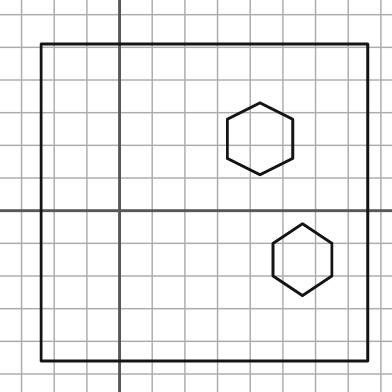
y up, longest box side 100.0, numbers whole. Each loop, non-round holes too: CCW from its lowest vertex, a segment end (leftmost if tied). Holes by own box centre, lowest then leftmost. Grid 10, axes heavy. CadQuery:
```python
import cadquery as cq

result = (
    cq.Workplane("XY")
    .moveTo(-24.0, -46.0)
    .lineTo(76.0, -46.0)
    .lineTo(76.0, 51.0)
    .lineTo(-24.0, 51.0)
    .close()
    .moveTo(56.0, -26.0)
    .lineTo(65.0, -20.0)
    .lineTo(65.0, -10.0)
    .lineTo(56.0, -4.0)
    .lineTo(47.0, -10.0)
    .lineTo(47.0, -20.0)
    .close()
    .moveTo(43.0, 11.0)
    .lineTo(53.0, 16.0)
    .lineTo(53.0, 28.0)
    .lineTo(43.0, 33.0)
    .lineTo(33.0, 28.0)
    .lineTo(33.0, 16.0)
    .close()
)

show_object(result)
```